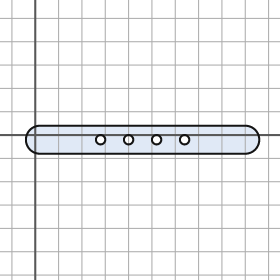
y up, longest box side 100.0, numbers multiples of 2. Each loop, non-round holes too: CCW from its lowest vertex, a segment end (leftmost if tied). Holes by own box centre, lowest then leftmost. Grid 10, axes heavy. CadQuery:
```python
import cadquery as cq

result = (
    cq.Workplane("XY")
    .moveTo(2.0, -8.0)
    .lineTo(90.0, -8.0)
    .threePointArc((96.0, -2.0), (90.0, 4.0))
    .lineTo(2.0, 4.0)
    .threePointArc((-4.0, -2.0), (2.0, -8.0))
    .close()
    .moveTo(28.0, -2.0)
    .circle(2.0)
    .moveTo(40.0, -2.0)
    .circle(2.0)
    .moveTo(52.0, -2.0)
    .circle(2.0)
    .moveTo(64.0, -2.0)
    .circle(2.0)
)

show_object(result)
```